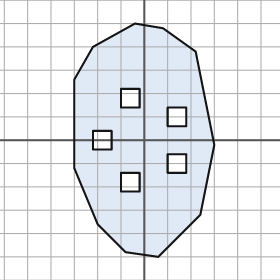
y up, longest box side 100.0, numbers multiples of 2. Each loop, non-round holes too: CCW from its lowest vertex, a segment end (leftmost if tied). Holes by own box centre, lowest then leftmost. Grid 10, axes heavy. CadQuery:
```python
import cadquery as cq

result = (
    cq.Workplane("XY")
    .moveTo(6.0, -50.0)
    .lineTo(24.0, -32.0)
    .lineTo(30.0, -2.0)
    .lineTo(22.0, 38.0)
    .lineTo(8.0, 48.0)
    .lineTo(-4.0, 50.0)
    .lineTo(-22.0, 40.0)
    .lineTo(-30.0, 26.0)
    .lineTo(-30.0, -12.0)
    .lineTo(-20.0, -36.0)
    .lineTo(-8.0, -48.0)
    .close()
    .moveTo(-10.0, -22.0)
    .lineTo(-2.0, -22.0)
    .lineTo(-2.0, -14.0)
    .lineTo(-10.0, -14.0)
    .close()
    .moveTo(10.0, -14.0)
    .lineTo(18.0, -14.0)
    .lineTo(18.0, -6.0)
    .lineTo(10.0, -6.0)
    .close()
    .moveTo(-22.0, -4.0)
    .lineTo(-14.0, -4.0)
    .lineTo(-14.0, 4.0)
    .lineTo(-22.0, 4.0)
    .close()
    .moveTo(10.0, 6.0)
    .lineTo(18.0, 6.0)
    .lineTo(18.0, 14.0)
    .lineTo(10.0, 14.0)
    .close()
    .moveTo(-10.0, 14.0)
    .lineTo(-2.0, 14.0)
    .lineTo(-2.0, 22.0)
    .lineTo(-10.0, 22.0)
    .close()
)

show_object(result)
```